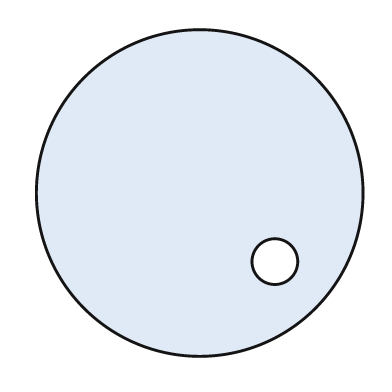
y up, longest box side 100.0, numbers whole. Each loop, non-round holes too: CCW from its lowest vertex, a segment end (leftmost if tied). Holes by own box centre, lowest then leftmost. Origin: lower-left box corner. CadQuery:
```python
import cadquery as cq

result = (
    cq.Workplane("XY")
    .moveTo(50.0, 50.0)
    .circle(50.0)
    .moveTo(73.0, 29.0)
    .circle(7.0)
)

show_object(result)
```